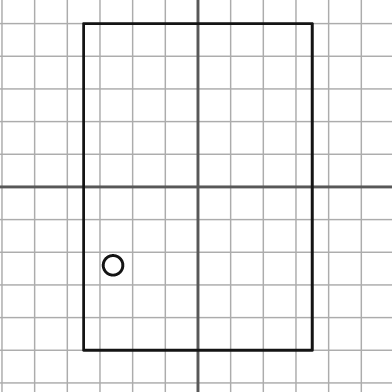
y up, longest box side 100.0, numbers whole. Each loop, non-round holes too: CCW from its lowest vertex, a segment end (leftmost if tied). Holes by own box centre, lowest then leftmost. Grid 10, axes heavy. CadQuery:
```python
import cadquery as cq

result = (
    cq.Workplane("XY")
    .moveTo(-35.0, -50.0)
    .lineTo(35.0, -50.0)
    .lineTo(35.0, 50.0)
    .lineTo(-35.0, 50.0)
    .close()
    .moveTo(-26.0, -24.0)
    .circle(3.0)
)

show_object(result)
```